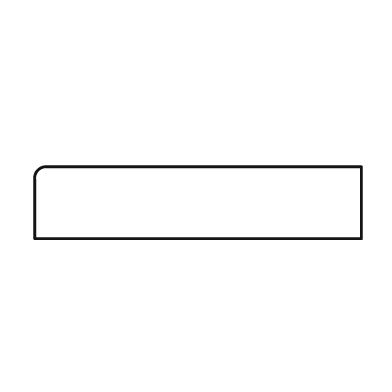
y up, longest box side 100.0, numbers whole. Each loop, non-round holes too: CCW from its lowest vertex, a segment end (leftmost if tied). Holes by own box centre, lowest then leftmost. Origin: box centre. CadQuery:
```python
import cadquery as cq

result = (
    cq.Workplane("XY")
    .moveTo(-50.0, -11.0)
    .lineTo(50.0, -11.0)
    .lineTo(50.0, 11.0)
    .lineTo(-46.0, 11.0)
    .threePointArc((-49.0, 10.0), (-50.0, 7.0))
    .close()
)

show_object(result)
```